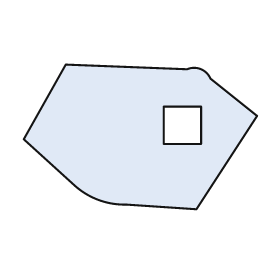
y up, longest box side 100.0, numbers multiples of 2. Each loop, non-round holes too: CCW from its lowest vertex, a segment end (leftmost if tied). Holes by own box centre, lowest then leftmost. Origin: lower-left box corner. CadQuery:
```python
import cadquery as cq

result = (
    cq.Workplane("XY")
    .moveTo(74.0, 0.0)
    .lineTo(100.0, 40.0)
    .lineTo(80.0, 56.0)
    .threePointArc((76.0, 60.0), (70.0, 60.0))
    .lineTo(18.0, 62.0)
    .lineTo(0.0, 30.0)
    .lineTo(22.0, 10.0)
    .threePointArc((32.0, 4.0), (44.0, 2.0))
    .close()
    .moveTo(60.0, 28.0)
    .lineTo(76.0, 28.0)
    .lineTo(76.0, 44.0)
    .lineTo(60.0, 44.0)
    .close()
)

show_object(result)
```